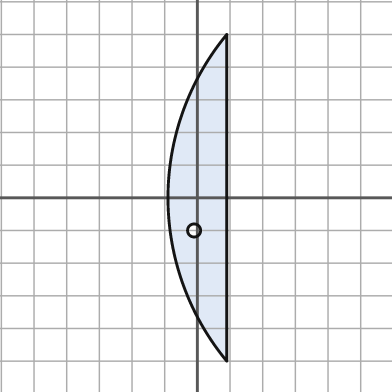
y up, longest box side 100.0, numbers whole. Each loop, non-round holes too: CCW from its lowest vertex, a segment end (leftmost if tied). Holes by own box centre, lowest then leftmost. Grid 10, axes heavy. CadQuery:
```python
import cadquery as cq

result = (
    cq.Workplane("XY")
    .moveTo(9.0, -50.0)
    .lineTo(9.0, 50.0)
    .threePointArc((-9.0, 0.0), (9.0, -50.0))
    .close()
    .moveTo(-1.0, -10.0)
    .circle(2.0)
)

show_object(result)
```